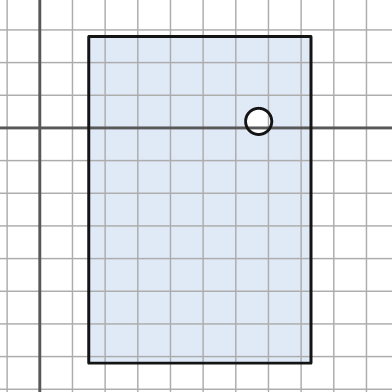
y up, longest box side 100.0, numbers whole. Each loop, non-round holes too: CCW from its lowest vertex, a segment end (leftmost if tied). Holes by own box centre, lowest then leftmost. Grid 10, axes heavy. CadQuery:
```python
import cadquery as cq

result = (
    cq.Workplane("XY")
    .moveTo(15.0, -72.0)
    .lineTo(83.0, -72.0)
    .lineTo(83.0, 28.0)
    .lineTo(15.0, 28.0)
    .close()
    .moveTo(67.0, 2.0)
    .circle(4.0)
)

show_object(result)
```